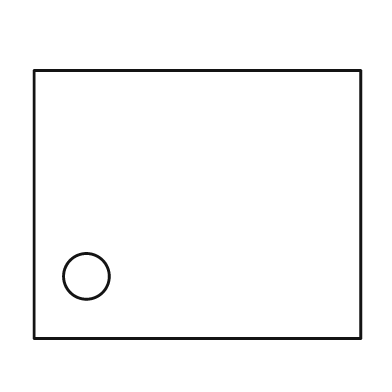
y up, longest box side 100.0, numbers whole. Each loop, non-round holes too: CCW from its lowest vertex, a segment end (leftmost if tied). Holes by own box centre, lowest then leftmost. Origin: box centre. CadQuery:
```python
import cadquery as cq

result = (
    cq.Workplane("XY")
    .moveTo(-50.0, -41.0)
    .lineTo(50.0, -41.0)
    .lineTo(50.0, 41.0)
    .lineTo(-50.0, 41.0)
    .close()
    .moveTo(-34.0, -22.0)
    .circle(7.0)
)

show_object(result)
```